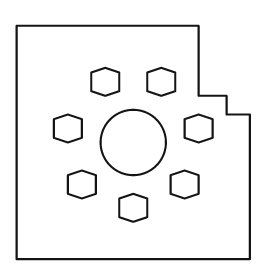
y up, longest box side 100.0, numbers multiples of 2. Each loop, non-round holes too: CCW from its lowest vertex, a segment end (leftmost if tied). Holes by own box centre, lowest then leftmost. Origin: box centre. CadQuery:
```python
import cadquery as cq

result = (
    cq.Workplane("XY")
    .moveTo(-50.0, -50.0)
    .lineTo(50.0, -50.0)
    .lineTo(50.0, 12.0)
    .lineTo(40.0, 12.0)
    .lineTo(40.0, 20.0)
    .lineTo(28.0, 20.0)
    .lineTo(28.0, 50.0)
    .lineTo(-50.0, 50.0)
    .close()
    .moveTo(0.0, -34.0)
    .lineTo(6.0, -32.0)
    .lineTo(6.0, -24.0)
    .lineTo(0.0, -22.0)
    .lineTo(-6.0, -24.0)
    .lineTo(-6.0, -32.0)
    .close()
    .moveTo(-22.0, -24.0)
    .lineTo(-16.0, -22.0)
    .lineTo(-16.0, -14.0)
    .lineTo(-22.0, -12.0)
    .lineTo(-28.0, -14.0)
    .lineTo(-28.0, -22.0)
    .close()
    .moveTo(22.0, -24.0)
    .lineTo(28.0, -22.0)
    .lineTo(28.0, -14.0)
    .lineTo(22.0, -12.0)
    .lineTo(16.0, -14.0)
    .lineTo(16.0, -22.0)
    .close()
    .moveTo(0.0, 0.0)
    .circle(14.0)
    .moveTo(-28.0, 0.0)
    .lineTo(-22.0, 2.0)
    .lineTo(-22.0, 10.0)
    .lineTo(-28.0, 12.0)
    .lineTo(-34.0, 10.0)
    .lineTo(-34.0, 2.0)
    .close()
    .moveTo(28.0, 0.0)
    .lineTo(34.0, 2.0)
    .lineTo(34.0, 10.0)
    .lineTo(28.0, 12.0)
    .lineTo(22.0, 10.0)
    .lineTo(22.0, 2.0)
    .close()
    .moveTo(-12.0, 20.0)
    .lineTo(-6.0, 22.0)
    .lineTo(-6.0, 30.0)
    .lineTo(-12.0, 32.0)
    .lineTo(-18.0, 30.0)
    .lineTo(-18.0, 22.0)
    .close()
    .moveTo(12.0, 20.0)
    .lineTo(18.0, 22.0)
    .lineTo(18.0, 30.0)
    .lineTo(12.0, 32.0)
    .lineTo(6.0, 30.0)
    .lineTo(6.0, 22.0)
    .close()
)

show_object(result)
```